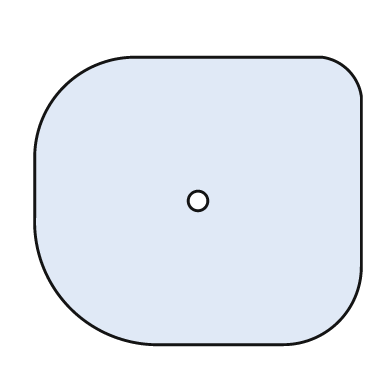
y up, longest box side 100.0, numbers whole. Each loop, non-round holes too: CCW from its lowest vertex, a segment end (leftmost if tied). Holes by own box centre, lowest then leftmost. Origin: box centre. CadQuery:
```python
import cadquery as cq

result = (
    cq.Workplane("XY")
    .moveTo(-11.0, -44.0)
    .lineTo(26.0, -44.0)
    .threePointArc((43.0, -37.0), (50.0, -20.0))
    .lineTo(50.0, 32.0)
    .threePointArc((46.0, 40.0), (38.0, 44.0))
    .lineTo(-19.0, 44.0)
    .threePointArc((-41.0, 35.0), (-50.0, 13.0))
    .lineTo(-50.0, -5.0)
    .threePointArc((-39.0, -33.0), (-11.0, -44.0))
    .close()
    .moveTo(0.0, 0.0)
    .circle(3.0)
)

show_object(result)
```